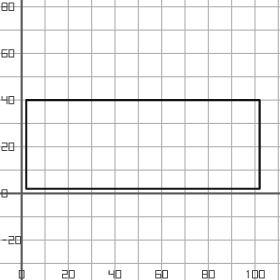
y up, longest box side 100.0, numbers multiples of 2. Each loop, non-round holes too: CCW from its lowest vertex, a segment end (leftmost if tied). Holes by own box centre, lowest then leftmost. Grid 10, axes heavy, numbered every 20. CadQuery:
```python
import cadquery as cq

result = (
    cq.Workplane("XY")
    .moveTo(2.0, 2.0)
    .lineTo(102.0, 2.0)
    .lineTo(102.0, 40.0)
    .lineTo(2.0, 40.0)
    .close()
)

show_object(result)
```